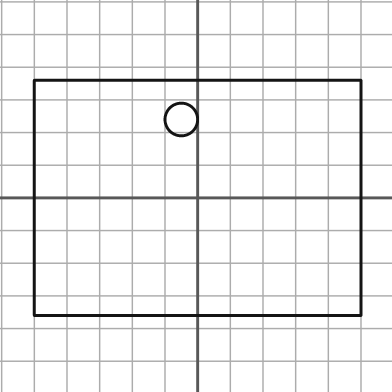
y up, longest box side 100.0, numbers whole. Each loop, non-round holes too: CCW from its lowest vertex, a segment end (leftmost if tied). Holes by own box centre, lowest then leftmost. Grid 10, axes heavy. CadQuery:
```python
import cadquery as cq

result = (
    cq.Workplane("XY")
    .moveTo(-50.0, -36.0)
    .lineTo(50.0, -36.0)
    .lineTo(50.0, 36.0)
    .lineTo(-50.0, 36.0)
    .close()
    .moveTo(-5.0, 24.0)
    .circle(5.0)
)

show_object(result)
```